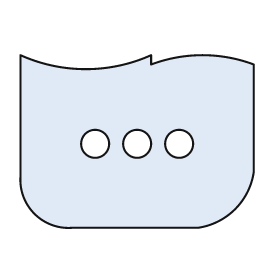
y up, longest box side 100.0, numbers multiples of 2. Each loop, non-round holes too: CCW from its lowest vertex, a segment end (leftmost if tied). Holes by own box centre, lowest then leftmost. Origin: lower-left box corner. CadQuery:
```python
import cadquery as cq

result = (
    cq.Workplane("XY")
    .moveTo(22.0, 0.0)
    .lineTo(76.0, 0.0)
    .threePointArc((92.0, 8.0), (100.0, 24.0))
    .lineTo(100.0, 70.0)
    .threePointArc((78.0, 74.0), (56.0, 70.0))
    .lineTo(56.0, 74.0)
    .threePointArc((28.0, 68.0), (0.0, 74.0))
    .lineTo(0.0, 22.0)
    .threePointArc((6.0, 6.0), (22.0, 0.0))
    .close()
    .moveTo(32.0, 36.0)
    .circle(6.0)
    .moveTo(50.0, 36.0)
    .circle(6.0)
    .moveTo(68.0, 36.0)
    .circle(6.0)
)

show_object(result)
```